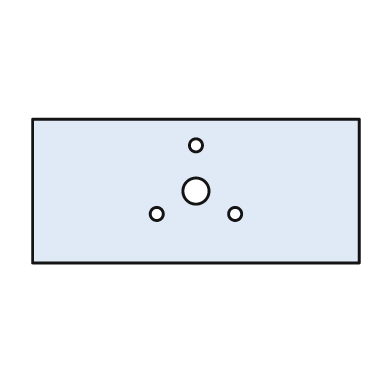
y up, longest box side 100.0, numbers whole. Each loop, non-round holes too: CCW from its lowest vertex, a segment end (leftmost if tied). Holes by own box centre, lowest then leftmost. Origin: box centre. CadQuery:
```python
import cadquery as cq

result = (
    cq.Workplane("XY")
    .moveTo(-50.0, -22.0)
    .lineTo(50.0, -22.0)
    .lineTo(50.0, 22.0)
    .lineTo(-50.0, 22.0)
    .close()
    .moveTo(-12.0, -7.0)
    .circle(2.0)
    .moveTo(12.0, -7.0)
    .circle(2.0)
    .moveTo(0.0, 0.0)
    .circle(4.0)
    .moveTo(0.0, 14.0)
    .circle(2.0)
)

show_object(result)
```